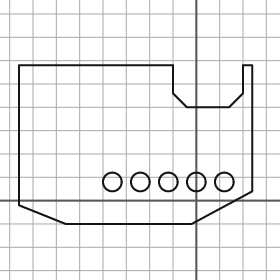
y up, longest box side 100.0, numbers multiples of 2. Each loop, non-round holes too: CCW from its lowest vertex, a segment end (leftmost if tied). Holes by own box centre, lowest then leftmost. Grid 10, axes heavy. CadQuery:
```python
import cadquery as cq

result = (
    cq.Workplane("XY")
    .moveTo(-56.0, -10.0)
    .lineTo(-2.0, -10.0)
    .lineTo(24.0, 4.0)
    .lineTo(24.0, 58.0)
    .lineTo(20.0, 58.0)
    .lineTo(20.0, 46.0)
    .lineTo(14.0, 40.0)
    .lineTo(-4.0, 40.0)
    .lineTo(-10.0, 46.0)
    .lineTo(-10.0, 58.0)
    .lineTo(-76.0, 58.0)
    .lineTo(-76.0, -2.0)
    .close()
    .moveTo(-36.0, 8.0)
    .circle(4.0)
    .moveTo(-24.0, 8.0)
    .circle(4.0)
    .moveTo(-12.0, 8.0)
    .circle(4.0)
    .moveTo(0.0, 8.0)
    .circle(4.0)
    .moveTo(12.0, 8.0)
    .circle(4.0)
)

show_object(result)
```